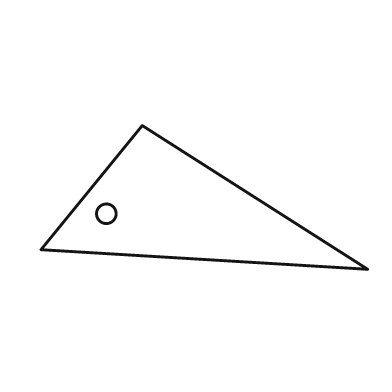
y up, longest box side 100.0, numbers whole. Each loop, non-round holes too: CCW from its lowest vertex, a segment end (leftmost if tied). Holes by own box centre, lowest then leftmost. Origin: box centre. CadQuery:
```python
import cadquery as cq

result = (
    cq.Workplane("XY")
    .moveTo(50.0, -22.0)
    .lineTo(-19.0, 22.0)
    .lineTo(-50.0, -16.0)
    .close()
    .moveTo(-30.0, -5.0)
    .circle(3.0)
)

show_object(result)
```